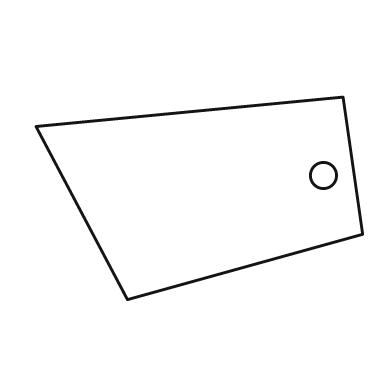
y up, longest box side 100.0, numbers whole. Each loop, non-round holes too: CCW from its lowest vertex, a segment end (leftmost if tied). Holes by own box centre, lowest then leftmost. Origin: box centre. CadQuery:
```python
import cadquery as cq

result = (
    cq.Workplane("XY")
    .moveTo(-22.0, -31.0)
    .lineTo(50.0, -11.0)
    .lineTo(44.0, 31.0)
    .lineTo(-50.0, 22.0)
    .close()
    .moveTo(38.0, 7.0)
    .circle(4.0)
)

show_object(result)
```